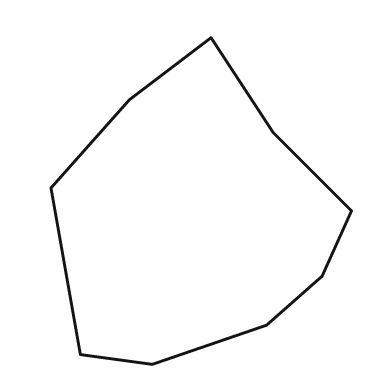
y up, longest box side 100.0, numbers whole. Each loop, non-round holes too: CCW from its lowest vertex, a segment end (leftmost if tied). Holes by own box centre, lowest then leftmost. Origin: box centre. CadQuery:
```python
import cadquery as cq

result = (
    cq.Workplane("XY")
    .moveTo(-15.0, -50.0)
    .lineTo(20.0, -38.0)
    .lineTo(37.0, -23.0)
    .lineTo(46.0, -3.0)
    .lineTo(22.0, 21.0)
    .lineTo(3.0, 50.0)
    .lineTo(-22.0, 31.0)
    .lineTo(-46.0, 4.0)
    .lineTo(-37.0, -47.0)
    .close()
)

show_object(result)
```